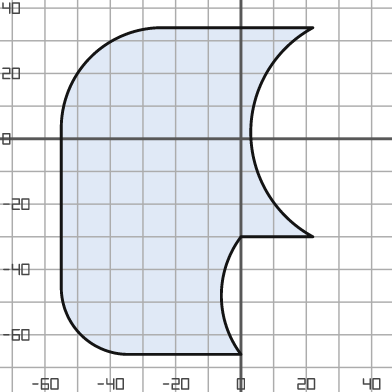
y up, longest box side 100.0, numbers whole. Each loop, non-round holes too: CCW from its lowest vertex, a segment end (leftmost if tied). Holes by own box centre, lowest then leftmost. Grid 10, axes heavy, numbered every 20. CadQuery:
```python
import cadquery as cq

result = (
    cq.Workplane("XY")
    .moveTo(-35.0, -66.0)
    .lineTo(0.0, -66.0)
    .threePointArc((-6.0, -48.0), (0.0, -30.0))
    .lineTo(22.0, -30.0)
    .threePointArc((3.0, 2.0), (22.0, 34.0))
    .lineTo(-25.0, 34.0)
    .threePointArc((-46.0, 25.0), (-55.0, 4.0))
    .lineTo(-55.0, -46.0)
    .threePointArc((-49.0, -60.0), (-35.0, -66.0))
    .close()
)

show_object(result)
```